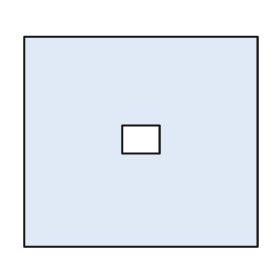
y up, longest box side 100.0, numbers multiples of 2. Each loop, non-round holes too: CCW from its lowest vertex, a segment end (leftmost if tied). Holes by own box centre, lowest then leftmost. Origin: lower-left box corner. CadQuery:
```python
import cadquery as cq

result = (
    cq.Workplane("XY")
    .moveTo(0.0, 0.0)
    .lineTo(100.0, 0.0)
    .lineTo(100.0, 90.0)
    .lineTo(0.0, 90.0)
    .close()
    .moveTo(42.0, 40.0)
    .lineTo(58.0, 40.0)
    .lineTo(58.0, 52.0)
    .lineTo(42.0, 52.0)
    .close()
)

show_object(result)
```